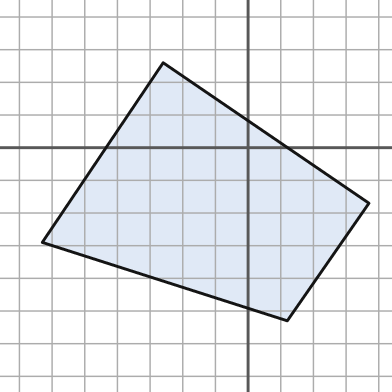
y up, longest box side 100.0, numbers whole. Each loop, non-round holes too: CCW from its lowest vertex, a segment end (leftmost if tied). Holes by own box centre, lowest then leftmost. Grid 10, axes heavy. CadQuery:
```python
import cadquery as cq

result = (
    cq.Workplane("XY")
    .moveTo(12.0, -53.0)
    .lineTo(37.0, -17.0)
    .lineTo(-26.0, 26.0)
    .lineTo(-63.0, -29.0)
    .close()
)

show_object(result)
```